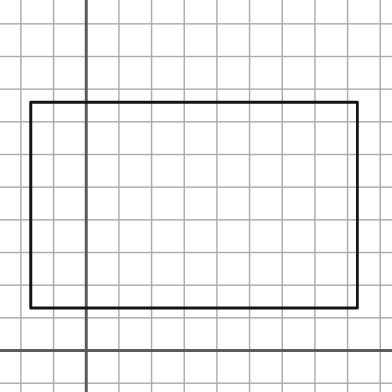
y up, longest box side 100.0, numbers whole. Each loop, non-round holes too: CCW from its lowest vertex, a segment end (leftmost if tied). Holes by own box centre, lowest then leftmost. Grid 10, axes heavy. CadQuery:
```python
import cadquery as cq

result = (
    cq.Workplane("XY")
    .moveTo(-17.0, 13.0)
    .lineTo(83.0, 13.0)
    .lineTo(83.0, 76.0)
    .lineTo(-17.0, 76.0)
    .close()
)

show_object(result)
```